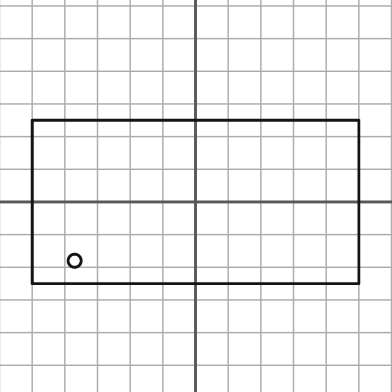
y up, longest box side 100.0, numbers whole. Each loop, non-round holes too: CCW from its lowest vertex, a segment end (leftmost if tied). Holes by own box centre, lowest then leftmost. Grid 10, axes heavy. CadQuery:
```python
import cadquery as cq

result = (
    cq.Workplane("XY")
    .moveTo(-50.0, -25.0)
    .lineTo(50.0, -25.0)
    .lineTo(50.0, 25.0)
    .lineTo(-50.0, 25.0)
    .close()
    .moveTo(-37.0, -18.0)
    .circle(2.0)
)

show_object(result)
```